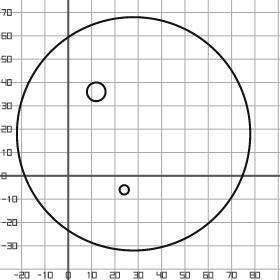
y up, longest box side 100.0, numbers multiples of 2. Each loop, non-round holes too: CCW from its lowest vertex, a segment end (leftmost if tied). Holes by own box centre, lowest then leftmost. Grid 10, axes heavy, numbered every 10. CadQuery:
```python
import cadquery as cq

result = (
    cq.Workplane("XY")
    .moveTo(28.0, 18.0)
    .circle(50.0)
    .moveTo(24.0, -6.0)
    .circle(2.0)
    .moveTo(12.0, 36.0)
    .circle(4.0)
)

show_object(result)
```